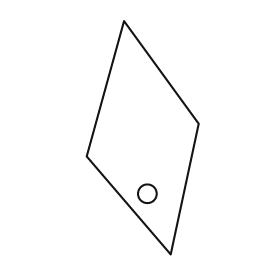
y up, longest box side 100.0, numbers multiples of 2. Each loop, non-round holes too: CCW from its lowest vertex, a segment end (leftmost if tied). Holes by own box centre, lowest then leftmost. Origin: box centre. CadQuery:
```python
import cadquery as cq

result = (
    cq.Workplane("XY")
    .moveTo(12.0, -50.0)
    .lineTo(24.0, 6.0)
    .lineTo(-8.0, 50.0)
    .lineTo(-24.0, -8.0)
    .close()
    .moveTo(2.0, -24.0)
    .circle(4.0)
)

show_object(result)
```